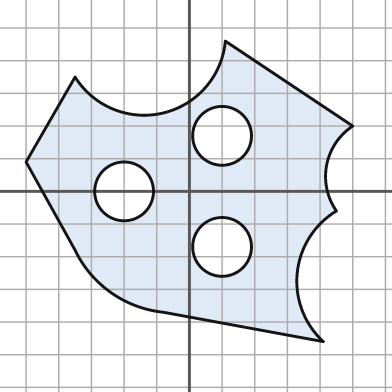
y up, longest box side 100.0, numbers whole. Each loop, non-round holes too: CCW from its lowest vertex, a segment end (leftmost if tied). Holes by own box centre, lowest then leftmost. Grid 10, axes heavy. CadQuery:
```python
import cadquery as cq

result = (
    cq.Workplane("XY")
    .moveTo(41.0, -46.0)
    .threePointArc((33.0, -25.0), (45.0, -6.0))
    .threePointArc((42.0, 8.0), (50.0, 20.0))
    .lineTo(11.0, 46.0)
    .threePointArc((-8.0, 24.0), (-35.0, 35.0))
    .lineTo(-50.0, 9.0)
    .lineTo(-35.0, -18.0)
    .threePointArc((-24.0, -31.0), (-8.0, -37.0))
    .close()
    .moveTo(10.0, -17.0)
    .circle(9.0)
    .moveTo(-20.0, 0.0)
    .circle(9.0)
    .moveTo(10.0, 17.0)
    .circle(9.0)
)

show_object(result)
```